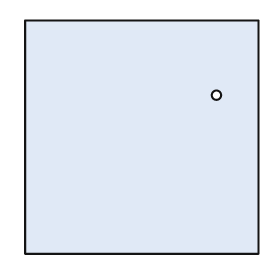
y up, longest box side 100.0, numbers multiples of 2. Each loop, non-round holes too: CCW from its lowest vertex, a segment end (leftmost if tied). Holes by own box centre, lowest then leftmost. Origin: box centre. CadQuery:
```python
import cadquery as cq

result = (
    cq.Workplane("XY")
    .moveTo(-50.0, -50.0)
    .lineTo(50.0, -50.0)
    .lineTo(50.0, 50.0)
    .lineTo(-50.0, 50.0)
    .close()
    .moveTo(32.0, 18.0)
    .circle(2.0)
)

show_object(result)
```